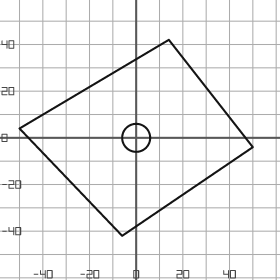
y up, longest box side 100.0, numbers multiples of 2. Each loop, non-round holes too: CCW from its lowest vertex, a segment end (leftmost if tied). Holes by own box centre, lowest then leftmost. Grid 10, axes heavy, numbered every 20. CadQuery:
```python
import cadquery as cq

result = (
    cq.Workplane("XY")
    .moveTo(-6.0, -42.0)
    .lineTo(50.0, -4.0)
    .lineTo(14.0, 42.0)
    .lineTo(-50.0, 4.0)
    .close()
    .moveTo(0.0, 0.0)
    .circle(6.0)
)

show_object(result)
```